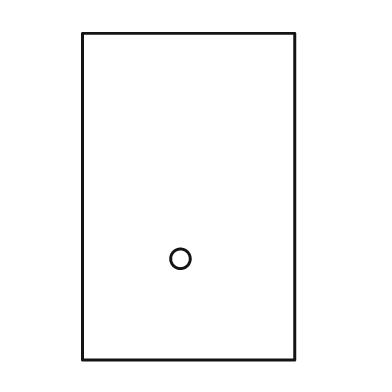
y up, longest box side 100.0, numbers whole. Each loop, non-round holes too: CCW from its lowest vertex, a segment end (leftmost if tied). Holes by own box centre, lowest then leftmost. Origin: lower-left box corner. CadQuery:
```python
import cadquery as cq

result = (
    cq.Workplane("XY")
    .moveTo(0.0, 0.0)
    .lineTo(65.0, 0.0)
    .lineTo(65.0, 100.0)
    .lineTo(0.0, 100.0)
    .close()
    .moveTo(30.0, 31.0)
    .circle(3.0)
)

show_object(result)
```